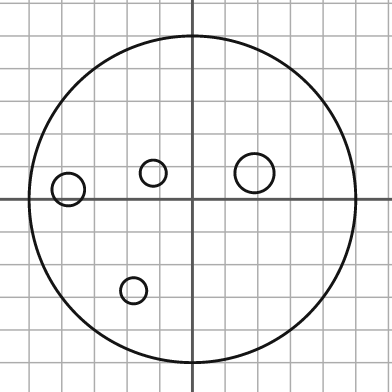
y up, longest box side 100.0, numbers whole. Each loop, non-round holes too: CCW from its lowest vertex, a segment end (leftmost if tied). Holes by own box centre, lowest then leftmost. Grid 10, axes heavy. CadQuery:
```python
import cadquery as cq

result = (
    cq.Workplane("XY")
    .moveTo(0.0, 0.0)
    .circle(50.0)
    .moveTo(-18.0, -28.0)
    .circle(4.0)
    .moveTo(-38.0, 3.0)
    .circle(5.0)
    .moveTo(-12.0, 8.0)
    .circle(4.0)
    .moveTo(19.0, 8.0)
    .circle(6.0)
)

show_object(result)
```